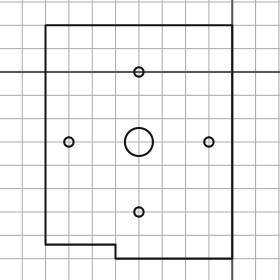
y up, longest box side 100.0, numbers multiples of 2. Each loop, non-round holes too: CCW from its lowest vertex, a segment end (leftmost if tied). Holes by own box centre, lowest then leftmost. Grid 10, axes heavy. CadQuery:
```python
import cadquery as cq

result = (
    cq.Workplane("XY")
    .moveTo(-50.0, -80.0)
    .lineTo(0.0, -80.0)
    .lineTo(0.0, 20.0)
    .lineTo(-80.0, 20.0)
    .lineTo(-80.0, -74.0)
    .lineTo(-50.0, -74.0)
    .close()
    .moveTo(-40.0, -60.0)
    .circle(2.0)
    .moveTo(-70.0, -30.0)
    .circle(2.0)
    .moveTo(-40.0, -30.0)
    .circle(6.0)
    .moveTo(-10.0, -30.0)
    .circle(2.0)
    .moveTo(-40.0, 0.0)
    .circle(2.0)
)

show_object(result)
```